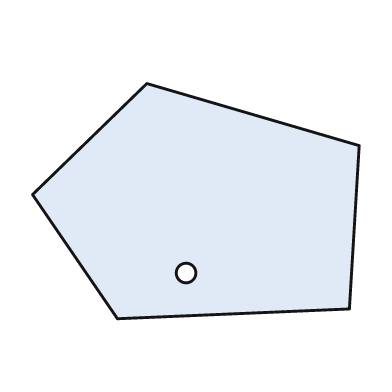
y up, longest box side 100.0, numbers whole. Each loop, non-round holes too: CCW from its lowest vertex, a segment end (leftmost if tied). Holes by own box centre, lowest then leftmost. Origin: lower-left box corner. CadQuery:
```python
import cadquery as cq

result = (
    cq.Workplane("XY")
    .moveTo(26.0, 0.0)
    .lineTo(97.0, 3.0)
    .lineTo(100.0, 53.0)
    .lineTo(35.0, 72.0)
    .lineTo(0.0, 38.0)
    .close()
    .moveTo(47.0, 14.0)
    .circle(3.0)
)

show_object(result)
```